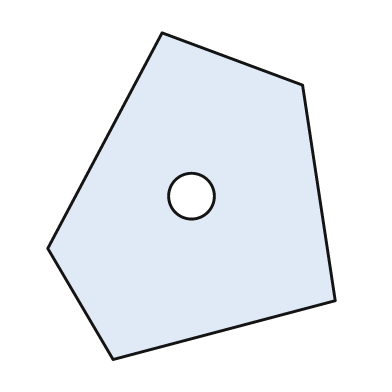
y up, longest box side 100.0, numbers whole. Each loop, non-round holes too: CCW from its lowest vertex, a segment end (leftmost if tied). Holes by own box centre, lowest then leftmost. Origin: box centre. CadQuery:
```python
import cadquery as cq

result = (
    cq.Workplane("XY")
    .moveTo(-24.0, -50.0)
    .lineTo(44.0, -32.0)
    .lineTo(34.0, 34.0)
    .lineTo(-9.0, 50.0)
    .lineTo(-44.0, -16.0)
    .close()
    .moveTo(0.0, 0.0)
    .circle(7.0)
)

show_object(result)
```